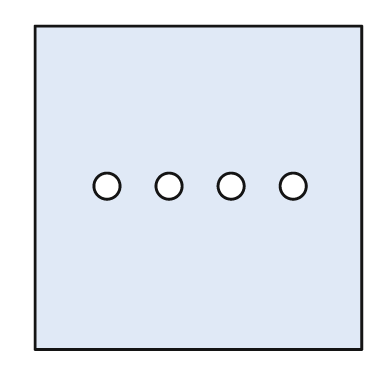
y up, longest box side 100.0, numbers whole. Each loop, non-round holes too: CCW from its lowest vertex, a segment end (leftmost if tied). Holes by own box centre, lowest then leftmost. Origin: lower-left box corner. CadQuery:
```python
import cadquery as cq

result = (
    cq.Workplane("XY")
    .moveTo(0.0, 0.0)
    .lineTo(100.0, 0.0)
    .lineTo(100.0, 99.0)
    .lineTo(0.0, 99.0)
    .close()
    .moveTo(22.0, 50.0)
    .circle(4.0)
    .moveTo(41.0, 50.0)
    .circle(4.0)
    .moveTo(60.0, 50.0)
    .circle(4.0)
    .moveTo(79.0, 50.0)
    .circle(4.0)
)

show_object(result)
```